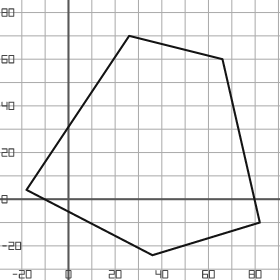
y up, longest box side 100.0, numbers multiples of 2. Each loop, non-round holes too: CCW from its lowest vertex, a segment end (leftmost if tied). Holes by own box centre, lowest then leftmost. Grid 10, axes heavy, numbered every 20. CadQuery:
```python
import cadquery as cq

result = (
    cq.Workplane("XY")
    .moveTo(36.0, -24.0)
    .lineTo(82.0, -10.0)
    .lineTo(66.0, 60.0)
    .lineTo(26.0, 70.0)
    .lineTo(-18.0, 4.0)
    .close()
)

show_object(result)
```